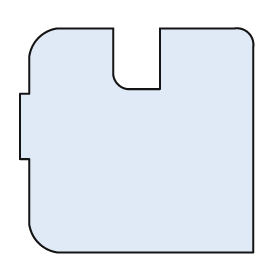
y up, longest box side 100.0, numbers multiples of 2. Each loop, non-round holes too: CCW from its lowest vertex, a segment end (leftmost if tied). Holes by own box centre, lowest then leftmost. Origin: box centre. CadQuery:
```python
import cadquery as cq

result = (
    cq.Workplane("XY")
    .moveTo(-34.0, -48.0)
    .lineTo(50.0, -48.0)
    .lineTo(50.0, 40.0)
    .threePointArc((48.0, 46.0), (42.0, 48.0))
    .lineTo(10.0, 48.0)
    .lineTo(10.0, 22.0)
    .lineTo(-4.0, 22.0)
    .threePointArc((-8.0, 24.0), (-10.0, 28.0))
    .lineTo(-10.0, 48.0)
    .lineTo(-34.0, 48.0)
    .threePointArc((-42.0, 44.0), (-46.0, 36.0))
    .lineTo(-46.0, 20.0)
    .lineTo(-50.0, 20.0)
    .lineTo(-50.0, -8.0)
    .lineTo(-46.0, -8.0)
    .lineTo(-46.0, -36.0)
    .threePointArc((-42.0, -44.0), (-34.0, -48.0))
    .close()
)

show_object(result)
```